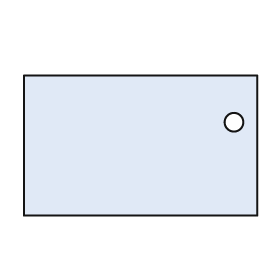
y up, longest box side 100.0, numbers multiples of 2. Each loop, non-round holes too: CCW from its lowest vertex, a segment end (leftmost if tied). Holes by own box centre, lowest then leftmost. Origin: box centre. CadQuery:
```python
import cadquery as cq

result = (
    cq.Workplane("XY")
    .moveTo(-50.0, -30.0)
    .lineTo(50.0, -30.0)
    .lineTo(50.0, 30.0)
    .lineTo(-50.0, 30.0)
    .close()
    .moveTo(40.0, 10.0)
    .circle(4.0)
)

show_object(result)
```